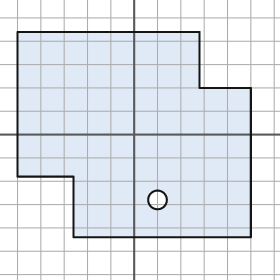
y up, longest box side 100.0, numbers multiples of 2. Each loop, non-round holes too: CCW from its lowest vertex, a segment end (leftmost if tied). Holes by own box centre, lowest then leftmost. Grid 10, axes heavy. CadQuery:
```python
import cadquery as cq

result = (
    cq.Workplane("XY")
    .moveTo(-26.0, -44.0)
    .lineTo(50.0, -44.0)
    .lineTo(50.0, 20.0)
    .lineTo(28.0, 20.0)
    .lineTo(28.0, 44.0)
    .lineTo(-50.0, 44.0)
    .lineTo(-50.0, -18.0)
    .lineTo(-26.0, -18.0)
    .close()
    .moveTo(10.0, -28.0)
    .circle(4.0)
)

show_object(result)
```